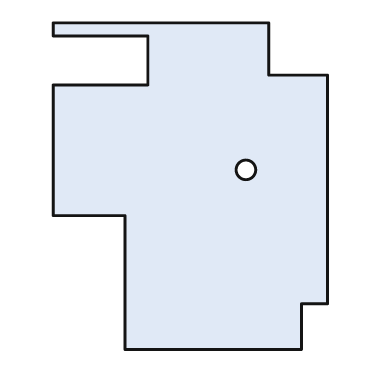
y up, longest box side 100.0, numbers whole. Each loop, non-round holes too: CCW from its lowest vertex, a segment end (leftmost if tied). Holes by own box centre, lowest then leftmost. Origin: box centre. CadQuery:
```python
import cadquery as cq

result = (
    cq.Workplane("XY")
    .moveTo(-20.0, -50.0)
    .lineTo(34.0, -50.0)
    .lineTo(34.0, -36.0)
    .lineTo(42.0, -36.0)
    .lineTo(42.0, 34.0)
    .lineTo(24.0, 34.0)
    .lineTo(24.0, 50.0)
    .lineTo(-42.0, 50.0)
    .lineTo(-42.0, 46.0)
    .lineTo(-13.0, 46.0)
    .lineTo(-13.0, 31.0)
    .lineTo(-42.0, 31.0)
    .lineTo(-42.0, -9.0)
    .lineTo(-20.0, -9.0)
    .close()
    .moveTo(17.0, 5.0)
    .circle(3.0)
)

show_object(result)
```